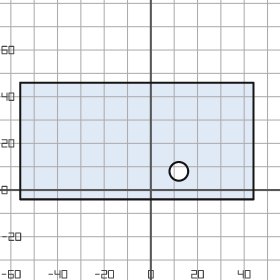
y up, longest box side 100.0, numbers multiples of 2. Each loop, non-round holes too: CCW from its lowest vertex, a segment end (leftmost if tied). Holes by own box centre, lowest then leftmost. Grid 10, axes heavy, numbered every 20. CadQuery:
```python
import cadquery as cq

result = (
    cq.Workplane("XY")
    .moveTo(-56.0, -4.0)
    .lineTo(44.0, -4.0)
    .lineTo(44.0, 46.0)
    .lineTo(-56.0, 46.0)
    .close()
    .moveTo(12.0, 8.0)
    .circle(4.0)
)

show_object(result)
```